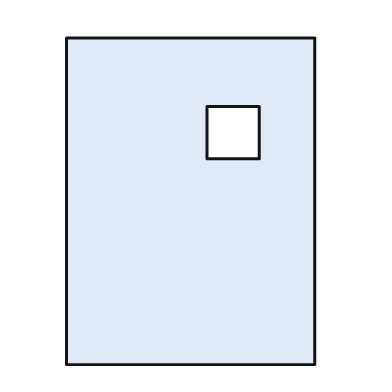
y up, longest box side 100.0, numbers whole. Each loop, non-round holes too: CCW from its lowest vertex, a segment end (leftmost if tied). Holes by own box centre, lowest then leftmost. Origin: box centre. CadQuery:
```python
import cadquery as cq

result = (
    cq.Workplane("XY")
    .moveTo(-38.0, -50.0)
    .lineTo(38.0, -50.0)
    .lineTo(38.0, 50.0)
    .lineTo(-38.0, 50.0)
    .close()
    .moveTo(5.0, 13.0)
    .lineTo(21.0, 13.0)
    .lineTo(21.0, 29.0)
    .lineTo(5.0, 29.0)
    .close()
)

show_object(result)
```